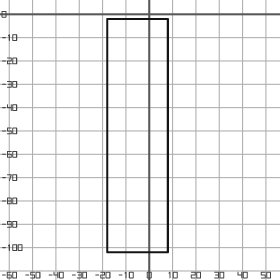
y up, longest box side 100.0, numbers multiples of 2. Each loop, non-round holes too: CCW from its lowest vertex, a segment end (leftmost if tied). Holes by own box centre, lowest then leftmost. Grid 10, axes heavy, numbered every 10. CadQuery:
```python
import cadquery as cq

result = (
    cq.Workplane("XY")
    .moveTo(-18.0, -102.0)
    .lineTo(8.0, -102.0)
    .lineTo(8.0, -2.0)
    .lineTo(-18.0, -2.0)
    .close()
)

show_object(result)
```